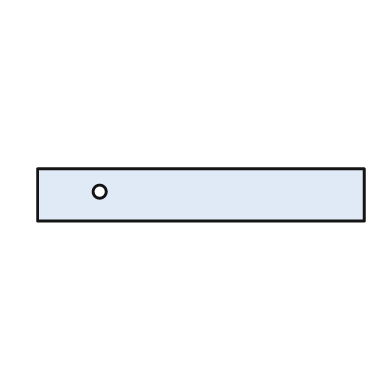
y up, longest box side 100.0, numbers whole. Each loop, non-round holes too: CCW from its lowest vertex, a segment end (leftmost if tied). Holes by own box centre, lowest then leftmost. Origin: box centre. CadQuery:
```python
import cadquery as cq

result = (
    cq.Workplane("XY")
    .moveTo(-50.0, -8.0)
    .lineTo(50.0, -8.0)
    .lineTo(50.0, 8.0)
    .lineTo(-50.0, 8.0)
    .close()
    .moveTo(-31.0, 1.0)
    .circle(2.0)
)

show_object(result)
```